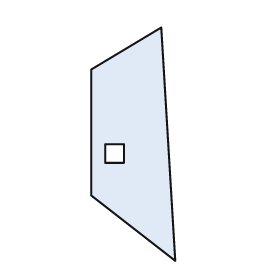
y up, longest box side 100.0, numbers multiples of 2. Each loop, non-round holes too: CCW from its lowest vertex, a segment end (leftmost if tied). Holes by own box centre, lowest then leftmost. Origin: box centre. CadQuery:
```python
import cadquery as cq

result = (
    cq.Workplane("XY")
    .moveTo(18.0, -50.0)
    .lineTo(12.0, 50.0)
    .lineTo(-18.0, 32.0)
    .lineTo(-18.0, -22.0)
    .close()
    .moveTo(-12.0, -8.0)
    .lineTo(-4.0, -8.0)
    .lineTo(-4.0, 0.0)
    .lineTo(-12.0, 0.0)
    .close()
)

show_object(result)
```